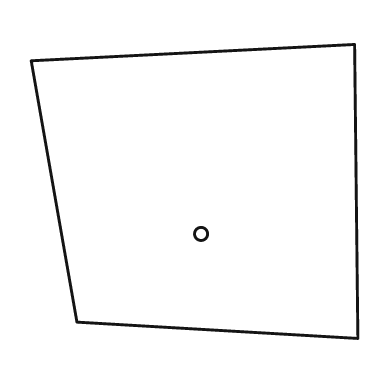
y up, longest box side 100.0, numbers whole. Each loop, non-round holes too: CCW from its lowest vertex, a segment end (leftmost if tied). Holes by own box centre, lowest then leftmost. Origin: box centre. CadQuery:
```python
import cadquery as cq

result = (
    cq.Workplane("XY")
    .moveTo(50.0, -45.0)
    .lineTo(49.0, 45.0)
    .lineTo(-50.0, 40.0)
    .lineTo(-36.0, -40.0)
    .close()
    .moveTo(2.0, -13.0)
    .circle(2.0)
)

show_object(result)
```